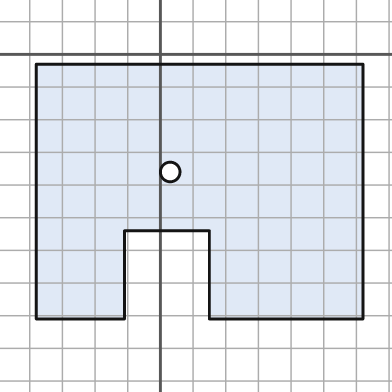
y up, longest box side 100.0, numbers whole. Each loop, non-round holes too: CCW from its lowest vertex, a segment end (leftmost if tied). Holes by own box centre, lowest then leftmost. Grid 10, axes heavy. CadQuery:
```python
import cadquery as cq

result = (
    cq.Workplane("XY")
    .moveTo(-38.0, -81.0)
    .lineTo(-11.0, -81.0)
    .lineTo(-11.0, -54.0)
    .lineTo(15.0, -54.0)
    .lineTo(15.0, -81.0)
    .lineTo(62.0, -81.0)
    .lineTo(62.0, -3.0)
    .lineTo(-38.0, -3.0)
    .close()
    .moveTo(3.0, -36.0)
    .circle(3.0)
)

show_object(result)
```